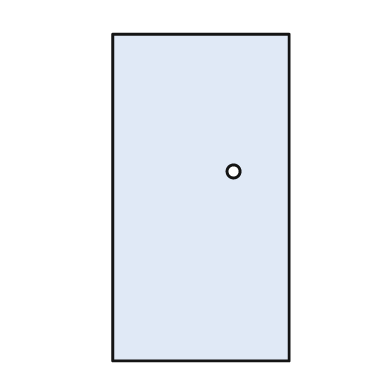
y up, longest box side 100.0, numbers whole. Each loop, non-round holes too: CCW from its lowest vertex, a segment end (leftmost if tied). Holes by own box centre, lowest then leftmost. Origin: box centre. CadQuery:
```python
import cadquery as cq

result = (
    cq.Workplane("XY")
    .moveTo(-27.0, -50.0)
    .lineTo(27.0, -50.0)
    .lineTo(27.0, 50.0)
    .lineTo(-27.0, 50.0)
    .close()
    .moveTo(10.0, 8.0)
    .circle(2.0)
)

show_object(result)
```